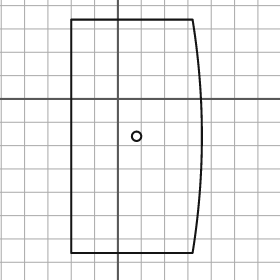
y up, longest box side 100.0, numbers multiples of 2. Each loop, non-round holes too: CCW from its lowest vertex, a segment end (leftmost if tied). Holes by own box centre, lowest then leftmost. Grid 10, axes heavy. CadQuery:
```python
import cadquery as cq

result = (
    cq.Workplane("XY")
    .moveTo(-20.0, -66.0)
    .lineTo(32.0, -66.0)
    .threePointArc((36.0, -16.0), (32.0, 34.0))
    .lineTo(-20.0, 34.0)
    .close()
    .moveTo(8.0, -16.0)
    .circle(2.0)
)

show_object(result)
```